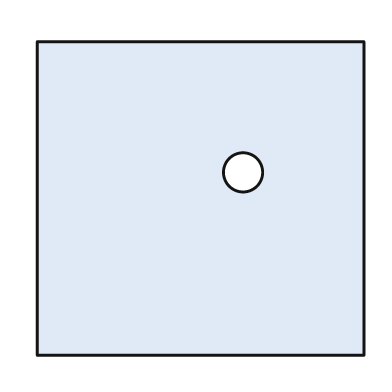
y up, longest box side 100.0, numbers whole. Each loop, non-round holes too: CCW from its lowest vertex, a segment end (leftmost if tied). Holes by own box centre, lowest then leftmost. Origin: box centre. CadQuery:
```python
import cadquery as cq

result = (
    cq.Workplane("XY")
    .moveTo(-50.0, -48.0)
    .lineTo(50.0, -48.0)
    .lineTo(50.0, 48.0)
    .lineTo(-50.0, 48.0)
    .close()
    .moveTo(13.0, 8.0)
    .circle(6.0)
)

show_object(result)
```